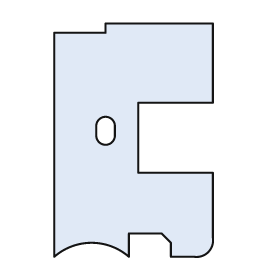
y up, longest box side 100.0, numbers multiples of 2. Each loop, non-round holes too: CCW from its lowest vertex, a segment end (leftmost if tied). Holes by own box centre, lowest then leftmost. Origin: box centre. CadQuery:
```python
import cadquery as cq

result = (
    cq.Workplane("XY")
    .moveTo(-34.0, -50.0)
    .threePointArc((-18.0, -44.0), (-2.0, -50.0))
    .lineTo(-2.0, -40.0)
    .lineTo(12.0, -40.0)
    .lineTo(16.0, -44.0)
    .lineTo(16.0, -50.0)
    .lineTo(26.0, -50.0)
    .threePointArc((32.0, -48.0), (34.0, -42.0))
    .lineTo(34.0, -14.0)
    .lineTo(2.0, -14.0)
    .lineTo(2.0, 16.0)
    .lineTo(34.0, 16.0)
    .lineTo(34.0, 50.0)
    .lineTo(-12.0, 50.0)
    .lineTo(-12.0, 46.0)
    .lineTo(-34.0, 46.0)
    .close()
    .moveTo(-16.0, 2.0)
    .threePointArc((-12.0, -2.0), (-8.0, 2.0))
    .lineTo(-8.0, 6.0)
    .threePointArc((-12.0, 10.0), (-16.0, 6.0))
    .close()
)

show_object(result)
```